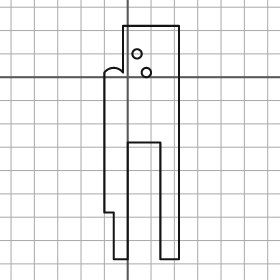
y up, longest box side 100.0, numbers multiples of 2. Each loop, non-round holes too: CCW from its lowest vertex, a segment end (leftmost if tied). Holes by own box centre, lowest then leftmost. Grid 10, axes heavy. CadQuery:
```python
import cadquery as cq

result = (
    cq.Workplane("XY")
    .moveTo(-6.0, -78.0)
    .lineTo(0.0, -78.0)
    .lineTo(0.0, -28.0)
    .lineTo(14.0, -28.0)
    .lineTo(14.0, -78.0)
    .lineTo(22.0, -78.0)
    .lineTo(22.0, 22.0)
    .lineTo(-2.0, 22.0)
    .lineTo(-2.0, 2.0)
    .threePointArc((-6.0, 4.0), (-10.0, 2.0))
    .lineTo(-10.0, -58.0)
    .lineTo(-6.0, -58.0)
    .close()
    .moveTo(8.0, 2.0)
    .circle(2.0)
    .moveTo(4.0, 10.0)
    .circle(2.0)
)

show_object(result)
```